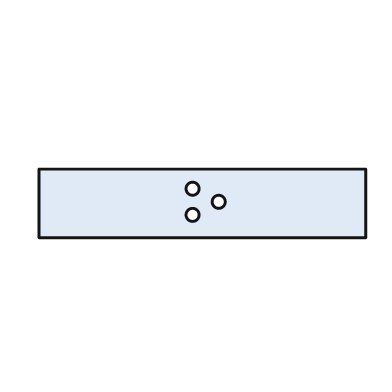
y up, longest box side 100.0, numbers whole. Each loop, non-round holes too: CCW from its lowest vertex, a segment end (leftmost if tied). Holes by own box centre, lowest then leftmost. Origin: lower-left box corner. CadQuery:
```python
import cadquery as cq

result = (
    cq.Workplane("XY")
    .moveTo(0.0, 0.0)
    .lineTo(100.0, 0.0)
    .lineTo(100.0, 21.0)
    .lineTo(0.0, 21.0)
    .close()
    .moveTo(47.0, 7.0)
    .circle(2.0)
    .moveTo(55.0, 11.0)
    .circle(2.0)
    .moveTo(47.0, 15.0)
    .circle(2.0)
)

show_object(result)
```